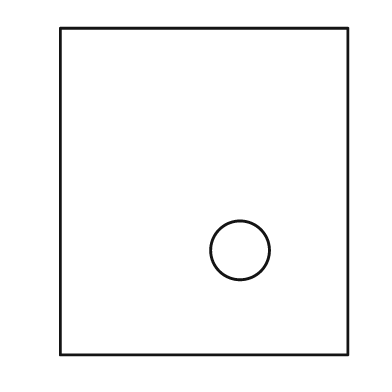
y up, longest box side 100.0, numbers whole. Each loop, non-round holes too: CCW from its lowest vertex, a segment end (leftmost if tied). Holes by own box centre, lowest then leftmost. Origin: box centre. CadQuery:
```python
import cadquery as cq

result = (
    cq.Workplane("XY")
    .moveTo(-44.0, -50.0)
    .lineTo(44.0, -50.0)
    .lineTo(44.0, 50.0)
    .lineTo(-44.0, 50.0)
    .close()
    .moveTo(11.0, -18.0)
    .circle(9.0)
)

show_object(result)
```